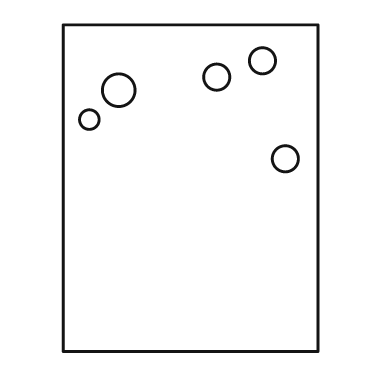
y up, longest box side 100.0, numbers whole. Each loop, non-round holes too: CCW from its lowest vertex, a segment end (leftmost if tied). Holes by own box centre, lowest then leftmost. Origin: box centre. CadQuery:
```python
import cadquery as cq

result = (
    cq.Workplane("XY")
    .moveTo(-39.0, -50.0)
    .lineTo(39.0, -50.0)
    .lineTo(39.0, 50.0)
    .lineTo(-39.0, 50.0)
    .close()
    .moveTo(29.0, 9.0)
    .circle(4.0)
    .moveTo(-31.0, 21.0)
    .circle(3.0)
    .moveTo(-22.0, 30.0)
    .circle(5.0)
    .moveTo(8.0, 34.0)
    .circle(4.0)
    .moveTo(22.0, 39.0)
    .circle(4.0)
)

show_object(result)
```